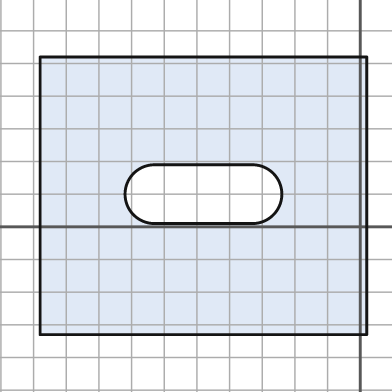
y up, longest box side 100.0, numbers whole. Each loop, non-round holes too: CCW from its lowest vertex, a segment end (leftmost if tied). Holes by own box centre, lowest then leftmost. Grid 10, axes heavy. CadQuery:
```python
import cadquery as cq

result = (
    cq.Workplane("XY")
    .moveTo(-98.0, -33.0)
    .lineTo(2.0, -33.0)
    .lineTo(2.0, 52.0)
    .lineTo(-98.0, 52.0)
    .close()
    .moveTo(-63.0, 1.0)
    .lineTo(-33.0, 1.0)
    .threePointArc((-24.0, 10.0), (-33.0, 19.0))
    .lineTo(-63.0, 19.0)
    .threePointArc((-72.0, 10.0), (-63.0, 1.0))
    .close()
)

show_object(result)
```